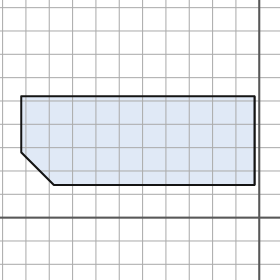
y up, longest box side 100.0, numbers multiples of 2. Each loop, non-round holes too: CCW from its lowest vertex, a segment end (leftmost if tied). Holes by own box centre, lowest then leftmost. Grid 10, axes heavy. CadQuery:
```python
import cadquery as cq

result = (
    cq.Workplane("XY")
    .moveTo(-88.0, 14.0)
    .lineTo(-2.0, 14.0)
    .lineTo(-2.0, 52.0)
    .lineTo(-102.0, 52.0)
    .lineTo(-102.0, 28.0)
    .close()
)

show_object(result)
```